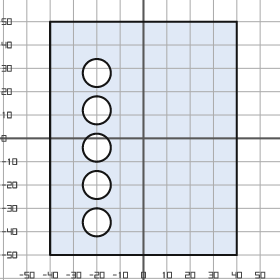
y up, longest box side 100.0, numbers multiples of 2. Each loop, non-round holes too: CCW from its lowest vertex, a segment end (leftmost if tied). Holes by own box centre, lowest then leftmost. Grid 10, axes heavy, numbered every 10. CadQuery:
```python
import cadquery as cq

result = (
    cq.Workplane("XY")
    .moveTo(-40.0, -50.0)
    .lineTo(40.0, -50.0)
    .lineTo(40.0, 50.0)
    .lineTo(-40.0, 50.0)
    .close()
    .moveTo(-20.0, -36.0)
    .circle(6.0)
    .moveTo(-20.0, -20.0)
    .circle(6.0)
    .moveTo(-20.0, -4.0)
    .circle(6.0)
    .moveTo(-20.0, 12.0)
    .circle(6.0)
    .moveTo(-20.0, 28.0)
    .circle(6.0)
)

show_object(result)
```